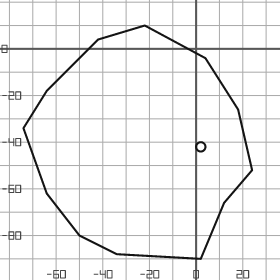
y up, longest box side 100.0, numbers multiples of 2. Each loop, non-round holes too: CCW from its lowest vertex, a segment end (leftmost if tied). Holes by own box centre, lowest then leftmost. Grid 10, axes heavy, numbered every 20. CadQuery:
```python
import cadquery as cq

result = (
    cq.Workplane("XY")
    .moveTo(2.0, -90.0)
    .lineTo(12.0, -66.0)
    .lineTo(24.0, -52.0)
    .lineTo(18.0, -26.0)
    .lineTo(4.0, -4.0)
    .lineTo(-22.0, 10.0)
    .lineTo(-42.0, 4.0)
    .lineTo(-64.0, -18.0)
    .lineTo(-74.0, -34.0)
    .lineTo(-64.0, -62.0)
    .lineTo(-50.0, -80.0)
    .lineTo(-34.0, -88.0)
    .close()
    .moveTo(2.0, -42.0)
    .circle(2.0)
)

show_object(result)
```